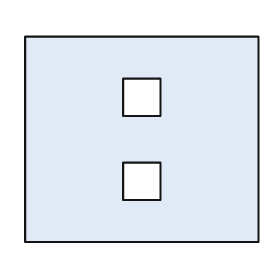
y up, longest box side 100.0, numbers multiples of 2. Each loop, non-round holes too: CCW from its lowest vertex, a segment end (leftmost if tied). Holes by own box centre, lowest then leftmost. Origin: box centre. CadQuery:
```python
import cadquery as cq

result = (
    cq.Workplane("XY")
    .moveTo(-50.0, -44.0)
    .lineTo(50.0, -44.0)
    .lineTo(50.0, 44.0)
    .lineTo(-50.0, 44.0)
    .close()
    .moveTo(-8.0, -26.0)
    .lineTo(8.0, -26.0)
    .lineTo(8.0, -10.0)
    .lineTo(-8.0, -10.0)
    .close()
    .moveTo(-8.0, 10.0)
    .lineTo(8.0, 10.0)
    .lineTo(8.0, 26.0)
    .lineTo(-8.0, 26.0)
    .close()
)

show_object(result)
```